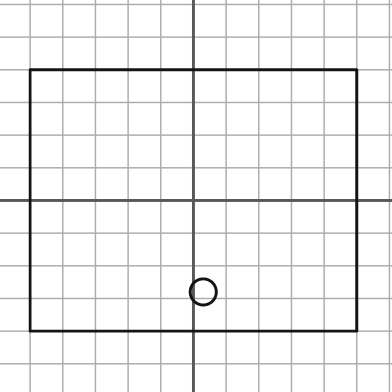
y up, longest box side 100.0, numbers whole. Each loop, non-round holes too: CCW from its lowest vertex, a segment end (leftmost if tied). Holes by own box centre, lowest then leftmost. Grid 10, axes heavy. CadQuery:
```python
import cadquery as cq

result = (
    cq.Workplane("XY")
    .moveTo(-50.0, -40.0)
    .lineTo(50.0, -40.0)
    .lineTo(50.0, 40.0)
    .lineTo(-50.0, 40.0)
    .close()
    .moveTo(3.0, -28.0)
    .circle(4.0)
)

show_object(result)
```